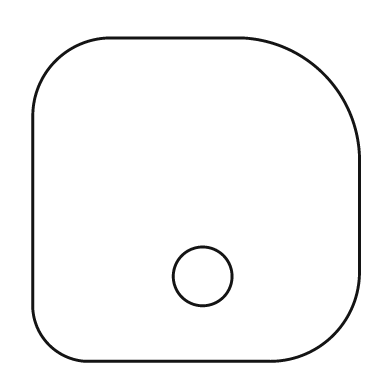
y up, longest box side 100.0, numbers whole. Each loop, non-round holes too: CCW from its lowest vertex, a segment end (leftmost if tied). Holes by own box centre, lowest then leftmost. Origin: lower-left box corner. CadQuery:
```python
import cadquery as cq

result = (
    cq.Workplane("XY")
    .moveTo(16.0, 0.0)
    .lineTo(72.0, 0.0)
    .threePointArc((92.0, 8.0), (100.0, 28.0))
    .lineTo(100.0, 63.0)
    .threePointArc((89.0, 88.0), (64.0, 99.0))
    .lineTo(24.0, 99.0)
    .threePointArc((7.0, 92.0), (0.0, 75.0))
    .lineTo(0.0, 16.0)
    .threePointArc((5.0, 5.0), (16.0, 0.0))
    .close()
    .moveTo(52.0, 26.0)
    .circle(9.0)
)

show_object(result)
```